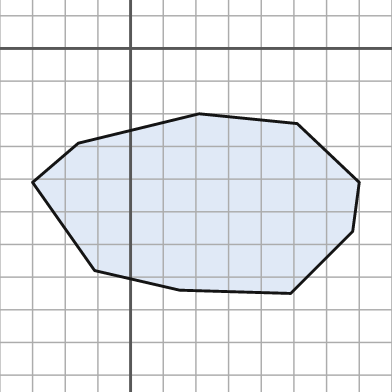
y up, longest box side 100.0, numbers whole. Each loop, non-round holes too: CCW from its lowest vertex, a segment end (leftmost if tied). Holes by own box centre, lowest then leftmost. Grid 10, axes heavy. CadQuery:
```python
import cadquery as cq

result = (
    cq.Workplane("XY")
    .moveTo(49.0, -75.0)
    .lineTo(68.0, -56.0)
    .lineTo(70.0, -41.0)
    .lineTo(51.0, -23.0)
    .lineTo(21.0, -20.0)
    .lineTo(-16.0, -29.0)
    .lineTo(-30.0, -41.0)
    .lineTo(-11.0, -68.0)
    .lineTo(15.0, -74.0)
    .close()
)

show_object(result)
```